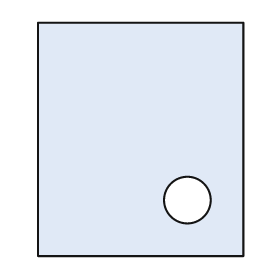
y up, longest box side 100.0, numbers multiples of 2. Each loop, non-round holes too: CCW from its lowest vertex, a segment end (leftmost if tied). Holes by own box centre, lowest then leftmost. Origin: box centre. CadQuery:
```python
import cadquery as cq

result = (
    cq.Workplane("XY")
    .moveTo(-44.0, -50.0)
    .lineTo(44.0, -50.0)
    .lineTo(44.0, 50.0)
    .lineTo(-44.0, 50.0)
    .close()
    .moveTo(20.0, -26.0)
    .circle(10.0)
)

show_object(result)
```